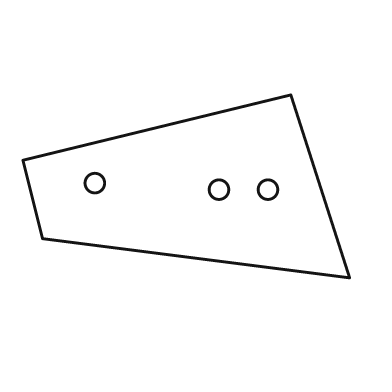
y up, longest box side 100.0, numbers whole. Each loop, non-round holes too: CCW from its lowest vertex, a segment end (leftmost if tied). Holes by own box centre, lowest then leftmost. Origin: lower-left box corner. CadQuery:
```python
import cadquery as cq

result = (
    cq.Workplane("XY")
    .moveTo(100.0, 0.0)
    .lineTo(82.0, 56.0)
    .lineTo(0.0, 36.0)
    .lineTo(6.0, 12.0)
    .close()
    .moveTo(60.0, 27.0)
    .circle(3.0)
    .moveTo(75.0, 27.0)
    .circle(3.0)
    .moveTo(22.0, 29.0)
    .circle(3.0)
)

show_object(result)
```